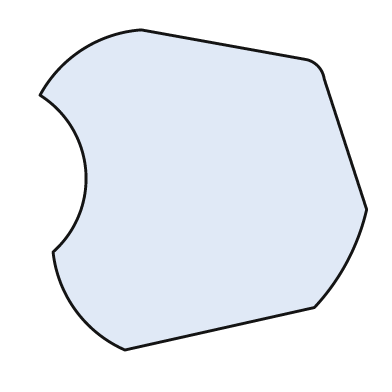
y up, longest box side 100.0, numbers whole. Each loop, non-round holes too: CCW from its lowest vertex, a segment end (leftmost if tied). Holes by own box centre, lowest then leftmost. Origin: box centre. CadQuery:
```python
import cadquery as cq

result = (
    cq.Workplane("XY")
    .moveTo(-24.0, -49.0)
    .lineTo(34.0, -36.0)
    .threePointArc((44.0, -22.0), (50.0, -6.0))
    .lineTo(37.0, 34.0)
    .threePointArc((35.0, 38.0), (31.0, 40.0))
    .lineTo(-19.0, 49.0)
    .threePointArc((-37.0, 43.0), (-50.0, 29.0))
    .threePointArc((-36.0, 6.0), (-46.0, -19.0))
    .threePointArc((-39.0, -37.0), (-24.0, -49.0))
    .close()
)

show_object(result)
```